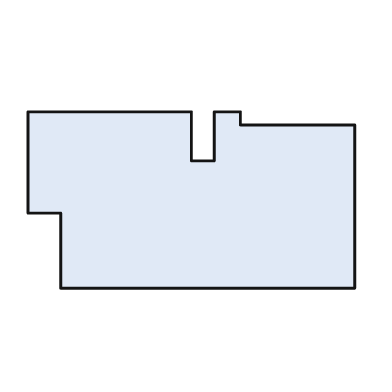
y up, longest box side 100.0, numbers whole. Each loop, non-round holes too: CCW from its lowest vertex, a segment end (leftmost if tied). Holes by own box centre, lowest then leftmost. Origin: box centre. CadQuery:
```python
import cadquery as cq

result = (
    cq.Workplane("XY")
    .moveTo(-40.0, -27.0)
    .lineTo(50.0, -27.0)
    .lineTo(50.0, 23.0)
    .lineTo(15.0, 23.0)
    .lineTo(15.0, 27.0)
    .lineTo(7.0, 27.0)
    .lineTo(7.0, 12.0)
    .lineTo(0.0, 12.0)
    .lineTo(0.0, 27.0)
    .lineTo(-50.0, 27.0)
    .lineTo(-50.0, -4.0)
    .lineTo(-40.0, -4.0)
    .close()
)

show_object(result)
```